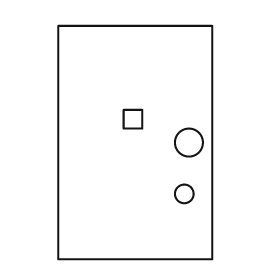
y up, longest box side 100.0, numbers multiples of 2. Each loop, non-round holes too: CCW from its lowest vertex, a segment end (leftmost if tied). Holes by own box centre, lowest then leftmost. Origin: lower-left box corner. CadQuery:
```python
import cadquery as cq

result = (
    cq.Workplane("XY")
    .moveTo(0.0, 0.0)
    .lineTo(66.0, 0.0)
    .lineTo(66.0, 100.0)
    .lineTo(0.0, 100.0)
    .close()
    .moveTo(54.0, 28.0)
    .circle(4.0)
    .moveTo(56.0, 50.0)
    .circle(6.0)
    .moveTo(28.0, 56.0)
    .lineTo(36.0, 56.0)
    .lineTo(36.0, 64.0)
    .lineTo(28.0, 64.0)
    .close()
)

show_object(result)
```